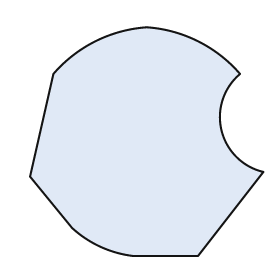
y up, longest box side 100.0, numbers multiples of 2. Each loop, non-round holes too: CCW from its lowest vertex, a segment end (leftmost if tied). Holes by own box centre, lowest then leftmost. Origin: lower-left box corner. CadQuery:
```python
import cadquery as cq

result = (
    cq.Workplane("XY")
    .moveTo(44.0, 0.0)
    .lineTo(72.0, 0.0)
    .lineTo(100.0, 36.0)
    .threePointArc((82.0, 54.0), (90.0, 78.0))
    .threePointArc((72.0, 92.0), (50.0, 98.0))
    .threePointArc((28.0, 92.0), (10.0, 78.0))
    .lineTo(0.0, 34.0)
    .lineTo(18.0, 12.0)
    .threePointArc((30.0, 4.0), (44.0, 0.0))
    .close()
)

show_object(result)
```